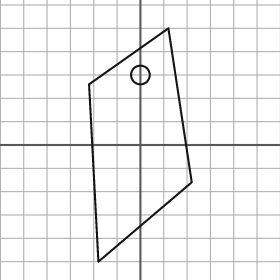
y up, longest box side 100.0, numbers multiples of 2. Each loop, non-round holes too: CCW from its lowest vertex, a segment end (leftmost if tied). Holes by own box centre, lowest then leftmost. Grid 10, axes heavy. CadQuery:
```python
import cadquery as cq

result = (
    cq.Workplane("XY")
    .moveTo(-18.0, -50.0)
    .lineTo(22.0, -16.0)
    .lineTo(12.0, 50.0)
    .lineTo(-22.0, 26.0)
    .close()
    .moveTo(0.0, 30.0)
    .circle(4.0)
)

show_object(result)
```